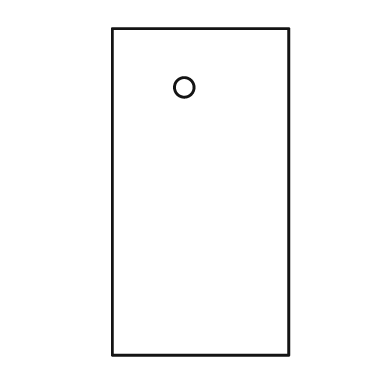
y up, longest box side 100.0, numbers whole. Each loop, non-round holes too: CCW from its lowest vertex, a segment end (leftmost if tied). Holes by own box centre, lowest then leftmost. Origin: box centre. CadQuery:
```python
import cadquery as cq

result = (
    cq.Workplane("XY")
    .moveTo(-27.0, -50.0)
    .lineTo(27.0, -50.0)
    .lineTo(27.0, 50.0)
    .lineTo(-27.0, 50.0)
    .close()
    .moveTo(-5.0, 32.0)
    .circle(3.0)
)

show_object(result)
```